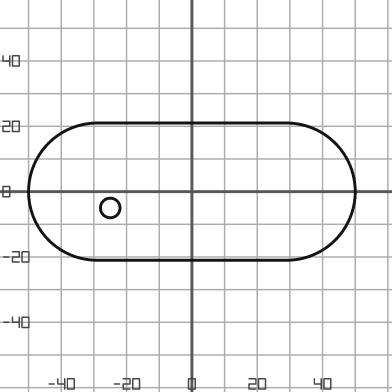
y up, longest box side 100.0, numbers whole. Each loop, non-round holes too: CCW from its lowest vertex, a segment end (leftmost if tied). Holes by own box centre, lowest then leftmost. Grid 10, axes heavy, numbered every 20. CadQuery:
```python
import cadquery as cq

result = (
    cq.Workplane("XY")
    .moveTo(-29.0, -21.0)
    .lineTo(29.0, -21.0)
    .threePointArc((50.0, 0.0), (29.0, 21.0))
    .lineTo(-29.0, 21.0)
    .threePointArc((-50.0, 0.0), (-29.0, -21.0))
    .close()
    .moveTo(-25.0, -5.0)
    .circle(3.0)
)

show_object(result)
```